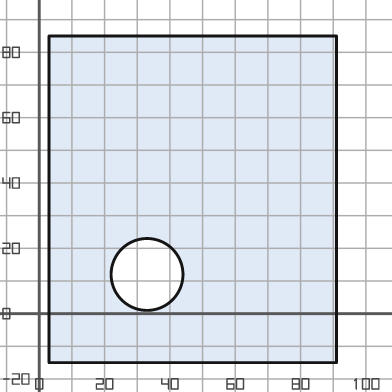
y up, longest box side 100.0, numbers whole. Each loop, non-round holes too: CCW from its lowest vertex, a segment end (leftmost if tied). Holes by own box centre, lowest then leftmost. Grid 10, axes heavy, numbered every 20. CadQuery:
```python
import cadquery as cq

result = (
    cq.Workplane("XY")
    .moveTo(3.0, -15.0)
    .lineTo(91.0, -15.0)
    .lineTo(91.0, 85.0)
    .lineTo(3.0, 85.0)
    .close()
    .moveTo(33.0, 12.0)
    .circle(11.0)
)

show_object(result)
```